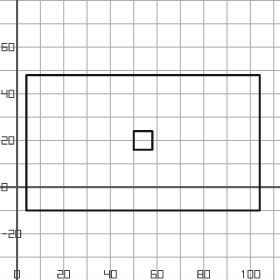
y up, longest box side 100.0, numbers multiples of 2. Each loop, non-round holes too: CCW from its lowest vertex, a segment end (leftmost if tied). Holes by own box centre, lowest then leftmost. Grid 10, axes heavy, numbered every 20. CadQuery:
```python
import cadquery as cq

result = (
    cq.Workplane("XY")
    .moveTo(4.0, -10.0)
    .lineTo(104.0, -10.0)
    .lineTo(104.0, 48.0)
    .lineTo(4.0, 48.0)
    .close()
    .moveTo(50.0, 16.0)
    .lineTo(58.0, 16.0)
    .lineTo(58.0, 24.0)
    .lineTo(50.0, 24.0)
    .close()
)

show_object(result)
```